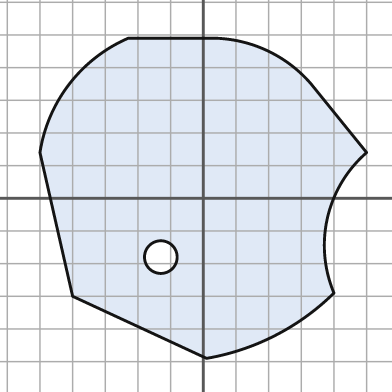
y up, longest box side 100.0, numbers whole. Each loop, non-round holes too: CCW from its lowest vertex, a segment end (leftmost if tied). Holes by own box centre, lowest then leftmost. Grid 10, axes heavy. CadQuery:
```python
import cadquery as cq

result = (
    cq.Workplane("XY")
    .moveTo(1.0, -49.0)
    .threePointArc((22.0, -42.0), (40.0, -29.0))
    .threePointArc((38.0, -6.0), (50.0, 14.0))
    .lineTo(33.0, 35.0)
    .threePointArc((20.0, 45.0), (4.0, 49.0))
    .lineTo(-23.0, 49.0)
    .threePointArc((-41.0, 35.0), (-50.0, 14.0))
    .lineTo(-40.0, -30.0)
    .close()
    .moveTo(-13.0, -18.0)
    .circle(5.0)
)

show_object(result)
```